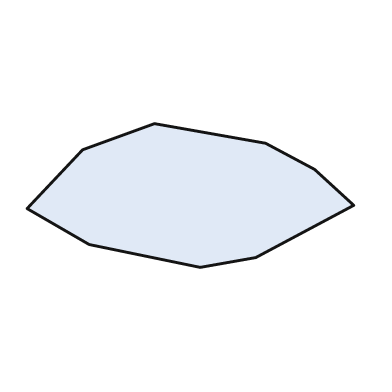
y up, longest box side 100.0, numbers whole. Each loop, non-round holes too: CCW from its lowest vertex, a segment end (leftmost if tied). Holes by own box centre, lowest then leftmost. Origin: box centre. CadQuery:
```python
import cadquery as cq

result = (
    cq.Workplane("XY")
    .moveTo(3.0, -22.0)
    .lineTo(20.0, -19.0)
    .lineTo(50.0, -3.0)
    .lineTo(38.0, 8.0)
    .lineTo(23.0, 16.0)
    .lineTo(-11.0, 22.0)
    .lineTo(-33.0, 14.0)
    .lineTo(-50.0, -4.0)
    .lineTo(-31.0, -15.0)
    .close()
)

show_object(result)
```